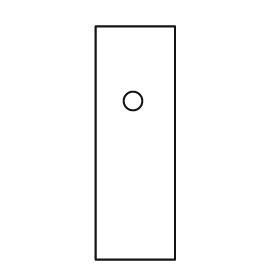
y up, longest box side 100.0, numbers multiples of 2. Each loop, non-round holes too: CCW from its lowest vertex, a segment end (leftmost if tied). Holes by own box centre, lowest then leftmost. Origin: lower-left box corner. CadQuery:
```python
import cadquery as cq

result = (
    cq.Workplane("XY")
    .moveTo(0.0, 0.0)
    .lineTo(34.0, 0.0)
    .lineTo(34.0, 100.0)
    .lineTo(0.0, 100.0)
    .close()
    .moveTo(16.0, 68.0)
    .circle(4.0)
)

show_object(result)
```